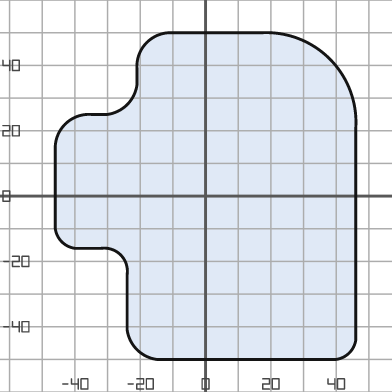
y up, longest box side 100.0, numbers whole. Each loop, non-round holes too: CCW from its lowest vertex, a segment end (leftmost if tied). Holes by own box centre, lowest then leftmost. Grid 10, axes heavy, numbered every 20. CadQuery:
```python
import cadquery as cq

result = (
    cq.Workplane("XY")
    .moveTo(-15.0, -50.0)
    .lineTo(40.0, -50.0)
    .threePointArc((44.0, -48.0), (46.0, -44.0))
    .lineTo(46.0, 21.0)
    .threePointArc((38.0, 42.0), (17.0, 50.0))
    .lineTo(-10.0, 50.0)
    .threePointArc((-18.0, 47.0), (-21.0, 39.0))
    .lineTo(-21.0, 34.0)
    .threePointArc((-24.0, 28.0), (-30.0, 25.0))
    .lineTo(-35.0, 25.0)
    .threePointArc((-43.0, 22.0), (-46.0, 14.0))
    .lineTo(-46.0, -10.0)
    .threePointArc((-44.0, -14.0), (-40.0, -16.0))
    .lineTo(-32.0, -16.0)
    .threePointArc((-26.0, -18.0), (-24.0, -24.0))
    .lineTo(-24.0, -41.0)
    .threePointArc((-21.0, -47.0), (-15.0, -50.0))
    .close()
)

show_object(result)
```